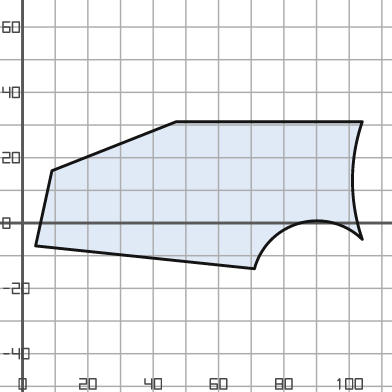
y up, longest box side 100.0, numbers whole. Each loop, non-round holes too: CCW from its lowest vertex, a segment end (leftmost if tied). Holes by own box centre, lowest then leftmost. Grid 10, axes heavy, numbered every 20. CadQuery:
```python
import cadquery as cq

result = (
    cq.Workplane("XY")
    .moveTo(71.0, -14.0)
    .threePointArc((85.0, 0.0), (104.0, -5.0))
    .threePointArc((101.0, 13.0), (104.0, 31.0))
    .lineTo(47.0, 31.0)
    .lineTo(9.0, 16.0)
    .lineTo(4.0, -7.0)
    .close()
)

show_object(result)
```